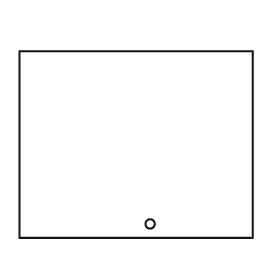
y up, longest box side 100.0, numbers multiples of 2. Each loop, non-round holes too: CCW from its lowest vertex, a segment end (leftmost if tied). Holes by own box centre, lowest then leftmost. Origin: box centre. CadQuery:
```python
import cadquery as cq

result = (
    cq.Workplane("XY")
    .moveTo(-50.0, -40.0)
    .lineTo(50.0, -40.0)
    .lineTo(50.0, 40.0)
    .lineTo(-50.0, 40.0)
    .close()
    .moveTo(6.0, -34.0)
    .circle(2.0)
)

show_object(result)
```